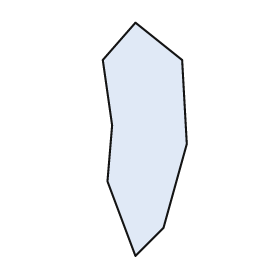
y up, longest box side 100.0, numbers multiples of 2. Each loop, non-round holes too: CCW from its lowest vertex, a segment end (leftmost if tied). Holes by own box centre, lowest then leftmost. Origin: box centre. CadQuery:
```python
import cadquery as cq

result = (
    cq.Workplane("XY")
    .moveTo(-4.0, -50.0)
    .lineTo(8.0, -38.0)
    .lineTo(18.0, -2.0)
    .lineTo(16.0, 34.0)
    .lineTo(-4.0, 50.0)
    .lineTo(-18.0, 34.0)
    .lineTo(-14.0, 6.0)
    .lineTo(-16.0, -18.0)
    .close()
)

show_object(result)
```